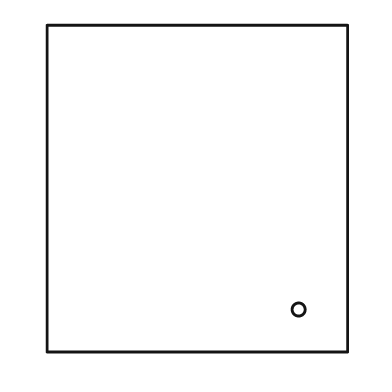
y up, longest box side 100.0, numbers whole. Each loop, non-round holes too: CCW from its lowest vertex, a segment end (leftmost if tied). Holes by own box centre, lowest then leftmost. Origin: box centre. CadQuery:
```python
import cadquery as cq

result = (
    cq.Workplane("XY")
    .moveTo(-46.0, -50.0)
    .lineTo(46.0, -50.0)
    .lineTo(46.0, 50.0)
    .lineTo(-46.0, 50.0)
    .close()
    .moveTo(31.0, -37.0)
    .circle(2.0)
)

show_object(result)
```